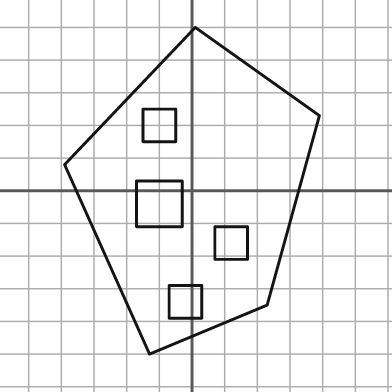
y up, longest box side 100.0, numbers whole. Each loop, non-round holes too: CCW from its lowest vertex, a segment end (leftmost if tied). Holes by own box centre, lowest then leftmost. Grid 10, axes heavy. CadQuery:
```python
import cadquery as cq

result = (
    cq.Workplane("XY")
    .moveTo(-13.0, -50.0)
    .lineTo(23.0, -35.0)
    .lineTo(39.0, 23.0)
    .lineTo(1.0, 50.0)
    .lineTo(-39.0, 8.0)
    .close()
    .moveTo(-7.0, -39.0)
    .lineTo(3.0, -39.0)
    .lineTo(3.0, -29.0)
    .lineTo(-7.0, -29.0)
    .close()
    .moveTo(7.0, -21.0)
    .lineTo(17.0, -21.0)
    .lineTo(17.0, -11.0)
    .lineTo(7.0, -11.0)
    .close()
    .moveTo(-17.0, -11.0)
    .lineTo(-3.0, -11.0)
    .lineTo(-3.0, 3.0)
    .lineTo(-17.0, 3.0)
    .close()
    .moveTo(-15.0, 15.0)
    .lineTo(-5.0, 15.0)
    .lineTo(-5.0, 25.0)
    .lineTo(-15.0, 25.0)
    .close()
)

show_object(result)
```